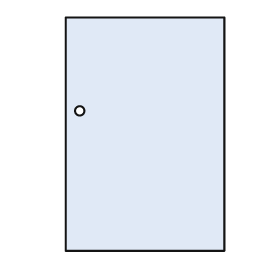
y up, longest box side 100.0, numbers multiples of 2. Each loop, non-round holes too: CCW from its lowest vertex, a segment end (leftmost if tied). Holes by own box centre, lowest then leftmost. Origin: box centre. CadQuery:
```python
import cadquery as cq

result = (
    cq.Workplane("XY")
    .moveTo(-34.0, -50.0)
    .lineTo(34.0, -50.0)
    .lineTo(34.0, 50.0)
    .lineTo(-34.0, 50.0)
    .close()
    .moveTo(-28.0, 10.0)
    .circle(2.0)
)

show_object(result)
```